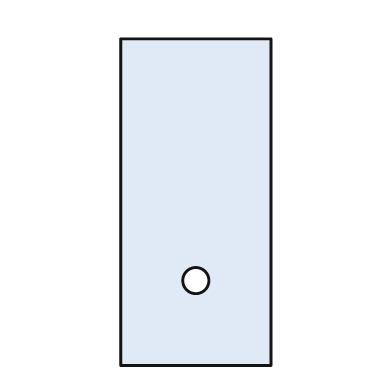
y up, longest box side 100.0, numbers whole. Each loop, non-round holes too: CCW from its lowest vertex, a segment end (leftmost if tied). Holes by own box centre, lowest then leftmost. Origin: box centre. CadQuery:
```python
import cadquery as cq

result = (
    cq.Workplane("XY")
    .moveTo(-23.0, -50.0)
    .lineTo(23.0, -50.0)
    .lineTo(23.0, 50.0)
    .lineTo(-23.0, 50.0)
    .close()
    .moveTo(0.0, -24.0)
    .circle(4.0)
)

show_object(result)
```